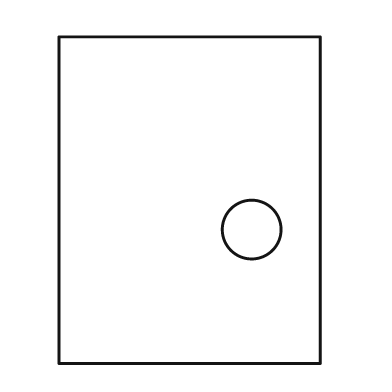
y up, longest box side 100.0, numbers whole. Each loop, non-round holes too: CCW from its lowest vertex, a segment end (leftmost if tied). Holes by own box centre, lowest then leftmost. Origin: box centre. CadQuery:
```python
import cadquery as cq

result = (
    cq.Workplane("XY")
    .moveTo(-40.0, -50.0)
    .lineTo(40.0, -50.0)
    .lineTo(40.0, 50.0)
    .lineTo(-40.0, 50.0)
    .close()
    .moveTo(19.0, -9.0)
    .circle(9.0)
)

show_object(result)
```